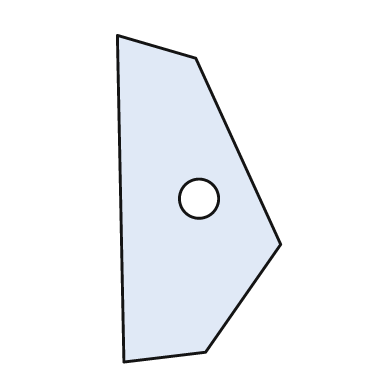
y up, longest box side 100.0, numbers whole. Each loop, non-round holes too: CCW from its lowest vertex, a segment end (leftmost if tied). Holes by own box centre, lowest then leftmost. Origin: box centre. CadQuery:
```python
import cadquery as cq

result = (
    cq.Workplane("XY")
    .moveTo(-23.0, -50.0)
    .lineTo(2.0, -47.0)
    .lineTo(25.0, -14.0)
    .lineTo(-1.0, 43.0)
    .lineTo(-25.0, 50.0)
    .close()
    .moveTo(0.0, 0.0)
    .circle(6.0)
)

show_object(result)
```